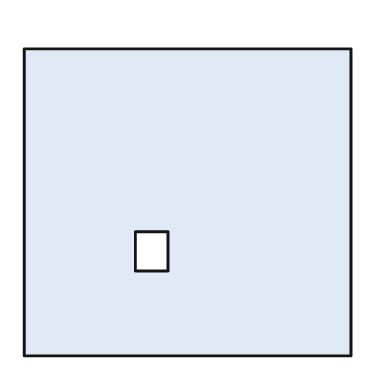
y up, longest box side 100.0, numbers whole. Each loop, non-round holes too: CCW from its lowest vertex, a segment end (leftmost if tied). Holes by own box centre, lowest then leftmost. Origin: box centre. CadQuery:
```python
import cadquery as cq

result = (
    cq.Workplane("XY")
    .moveTo(-50.0, -47.0)
    .lineTo(50.0, -47.0)
    .lineTo(50.0, 47.0)
    .lineTo(-50.0, 47.0)
    .close()
    .moveTo(-16.0, -21.0)
    .lineTo(-6.0, -21.0)
    .lineTo(-6.0, -9.0)
    .lineTo(-16.0, -9.0)
    .close()
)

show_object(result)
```